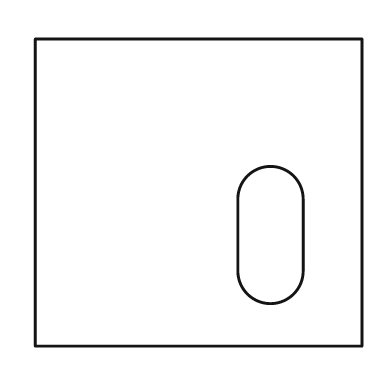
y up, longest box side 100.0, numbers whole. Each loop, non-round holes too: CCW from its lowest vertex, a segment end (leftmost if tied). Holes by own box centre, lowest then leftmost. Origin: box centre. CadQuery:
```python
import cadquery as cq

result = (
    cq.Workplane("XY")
    .moveTo(-50.0, -47.0)
    .lineTo(50.0, -47.0)
    .lineTo(50.0, 47.0)
    .lineTo(-50.0, 47.0)
    .close()
    .moveTo(12.0, -24.0)
    .threePointArc((22.0, -34.0), (32.0, -24.0))
    .lineTo(32.0, -2.0)
    .threePointArc((22.0, 8.0), (12.0, -2.0))
    .close()
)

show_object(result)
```